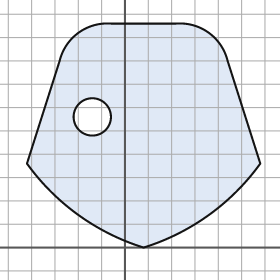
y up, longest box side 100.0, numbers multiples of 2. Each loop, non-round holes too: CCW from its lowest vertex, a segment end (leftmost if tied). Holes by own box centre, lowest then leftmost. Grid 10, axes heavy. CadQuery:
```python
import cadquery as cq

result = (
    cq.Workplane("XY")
    .moveTo(8.0, 0.0)
    .threePointArc((36.0, 14.0), (58.0, 36.0))
    .lineTo(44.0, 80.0)
    .threePointArc((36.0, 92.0), (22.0, 96.0))
    .lineTo(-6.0, 96.0)
    .threePointArc((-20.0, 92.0), (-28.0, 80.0))
    .lineTo(-42.0, 36.0)
    .threePointArc((-20.0, 14.0), (8.0, 0.0))
    .close()
    .moveTo(-14.0, 56.0)
    .circle(8.0)
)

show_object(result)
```